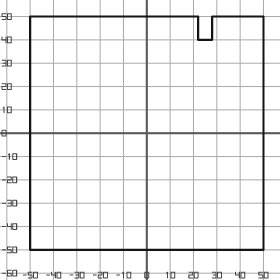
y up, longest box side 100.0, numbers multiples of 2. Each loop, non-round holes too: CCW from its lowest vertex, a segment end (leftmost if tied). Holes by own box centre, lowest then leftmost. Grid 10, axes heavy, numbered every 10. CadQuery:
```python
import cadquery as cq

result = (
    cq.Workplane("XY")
    .moveTo(-50.0, -50.0)
    .lineTo(50.0, -50.0)
    .lineTo(50.0, 50.0)
    .lineTo(28.0, 50.0)
    .lineTo(28.0, 40.0)
    .lineTo(22.0, 40.0)
    .lineTo(22.0, 50.0)
    .lineTo(-50.0, 50.0)
    .close()
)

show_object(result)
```